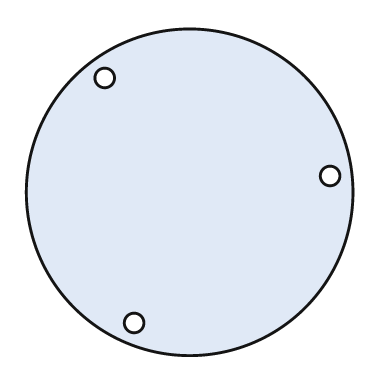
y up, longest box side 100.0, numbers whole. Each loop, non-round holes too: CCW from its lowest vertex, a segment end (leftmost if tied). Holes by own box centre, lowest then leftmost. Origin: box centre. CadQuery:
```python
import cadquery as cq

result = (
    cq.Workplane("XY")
    .moveTo(0.0, 0.0)
    .circle(50.0)
    .moveTo(-17.0, -40.0)
    .circle(3.0)
    .moveTo(43.0, 5.0)
    .circle(3.0)
    .moveTo(-26.0, 35.0)
    .circle(3.0)
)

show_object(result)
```